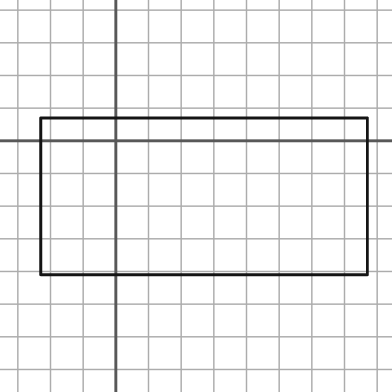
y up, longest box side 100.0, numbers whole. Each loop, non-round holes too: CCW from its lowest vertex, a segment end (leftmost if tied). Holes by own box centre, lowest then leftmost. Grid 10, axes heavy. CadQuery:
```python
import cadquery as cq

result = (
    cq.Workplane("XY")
    .moveTo(-23.0, -41.0)
    .lineTo(77.0, -41.0)
    .lineTo(77.0, 7.0)
    .lineTo(-23.0, 7.0)
    .close()
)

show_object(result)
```